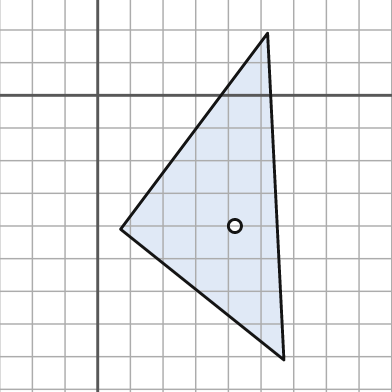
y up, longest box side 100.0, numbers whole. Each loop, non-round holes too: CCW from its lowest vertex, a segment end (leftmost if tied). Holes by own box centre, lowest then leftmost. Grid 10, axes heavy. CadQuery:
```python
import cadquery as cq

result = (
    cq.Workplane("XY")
    .moveTo(57.0, -81.0)
    .lineTo(52.0, 19.0)
    .lineTo(7.0, -41.0)
    .close()
    .moveTo(42.0, -40.0)
    .circle(2.0)
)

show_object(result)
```